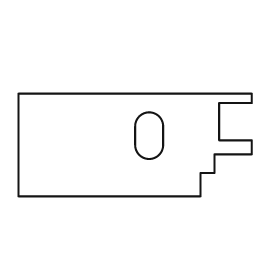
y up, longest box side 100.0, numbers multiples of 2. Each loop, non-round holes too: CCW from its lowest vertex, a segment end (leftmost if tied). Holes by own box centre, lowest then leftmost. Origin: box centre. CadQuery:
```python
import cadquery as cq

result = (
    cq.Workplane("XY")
    .moveTo(-50.0, -22.0)
    .lineTo(28.0, -22.0)
    .lineTo(28.0, -12.0)
    .lineTo(34.0, -12.0)
    .lineTo(34.0, -4.0)
    .lineTo(50.0, -4.0)
    .lineTo(50.0, 2.0)
    .lineTo(36.0, 2.0)
    .lineTo(36.0, 18.0)
    .lineTo(50.0, 18.0)
    .lineTo(50.0, 22.0)
    .lineTo(-50.0, 22.0)
    .close()
    .moveTo(0.0, 0.0)
    .threePointArc((6.0, -6.0), (12.0, 0.0))
    .lineTo(12.0, 8.0)
    .threePointArc((6.0, 14.0), (0.0, 8.0))
    .close()
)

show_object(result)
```